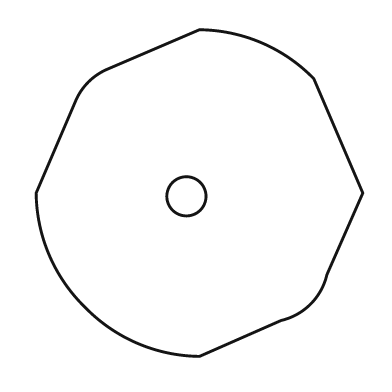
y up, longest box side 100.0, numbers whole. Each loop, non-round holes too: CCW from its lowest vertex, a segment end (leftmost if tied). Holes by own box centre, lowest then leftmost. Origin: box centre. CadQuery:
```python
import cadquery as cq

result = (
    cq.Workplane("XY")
    .moveTo(0.0, -50.0)
    .lineTo(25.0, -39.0)
    .threePointArc((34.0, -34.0), (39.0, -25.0))
    .lineTo(50.0, 0.0)
    .lineTo(35.0, 35.0)
    .threePointArc((19.0, 46.0), (0.0, 50.0))
    .lineTo(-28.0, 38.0)
    .threePointArc((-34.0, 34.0), (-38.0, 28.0))
    .lineTo(-50.0, 0.0)
    .threePointArc((-46.0, -19.0), (-35.0, -35.0))
    .threePointArc((-19.0, -46.0), (0.0, -50.0))
    .close()
    .moveTo(-4.0, -1.0)
    .circle(6.0)
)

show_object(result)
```